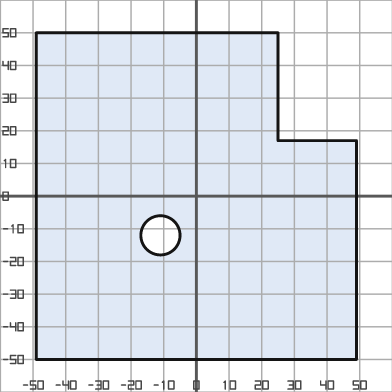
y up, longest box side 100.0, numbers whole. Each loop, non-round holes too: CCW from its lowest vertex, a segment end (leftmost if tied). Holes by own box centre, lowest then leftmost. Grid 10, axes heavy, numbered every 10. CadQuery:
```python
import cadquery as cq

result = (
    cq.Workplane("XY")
    .moveTo(-49.0, -50.0)
    .lineTo(49.0, -50.0)
    .lineTo(49.0, 17.0)
    .lineTo(25.0, 17.0)
    .lineTo(25.0, 50.0)
    .lineTo(-49.0, 50.0)
    .close()
    .moveTo(-11.0, -12.0)
    .circle(6.0)
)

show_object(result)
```